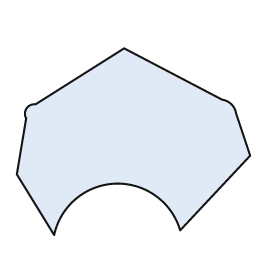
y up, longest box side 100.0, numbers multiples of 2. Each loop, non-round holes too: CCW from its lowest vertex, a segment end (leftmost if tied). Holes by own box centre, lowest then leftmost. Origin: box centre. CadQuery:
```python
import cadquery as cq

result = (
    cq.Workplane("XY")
    .moveTo(-34.0, -40.0)
    .threePointArc((-8.0, -18.0), (20.0, -38.0))
    .lineTo(50.0, -6.0)
    .lineTo(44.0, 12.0)
    .threePointArc((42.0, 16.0), (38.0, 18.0))
    .lineTo(-4.0, 40.0)
    .lineTo(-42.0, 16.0)
    .threePointArc((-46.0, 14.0), (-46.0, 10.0))
    .lineTo(-50.0, -14.0)
    .close()
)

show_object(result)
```